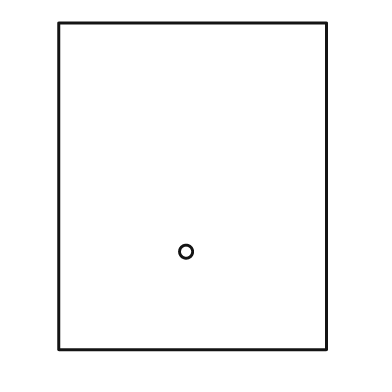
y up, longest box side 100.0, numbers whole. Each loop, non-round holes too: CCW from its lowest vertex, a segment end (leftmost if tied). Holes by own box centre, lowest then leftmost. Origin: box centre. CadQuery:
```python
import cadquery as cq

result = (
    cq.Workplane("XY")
    .moveTo(-41.0, -50.0)
    .lineTo(41.0, -50.0)
    .lineTo(41.0, 50.0)
    .lineTo(-41.0, 50.0)
    .close()
    .moveTo(-2.0, -20.0)
    .circle(2.0)
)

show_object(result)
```